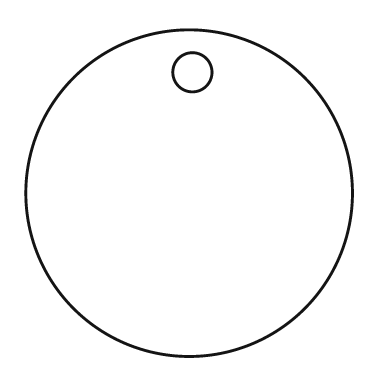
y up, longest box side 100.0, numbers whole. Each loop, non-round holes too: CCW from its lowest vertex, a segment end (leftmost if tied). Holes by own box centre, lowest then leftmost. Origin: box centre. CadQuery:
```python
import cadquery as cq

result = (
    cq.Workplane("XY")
    .moveTo(0.0, 0.0)
    .circle(50.0)
    .moveTo(1.0, 37.0)
    .circle(6.0)
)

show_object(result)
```